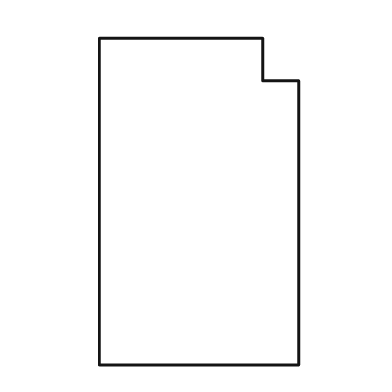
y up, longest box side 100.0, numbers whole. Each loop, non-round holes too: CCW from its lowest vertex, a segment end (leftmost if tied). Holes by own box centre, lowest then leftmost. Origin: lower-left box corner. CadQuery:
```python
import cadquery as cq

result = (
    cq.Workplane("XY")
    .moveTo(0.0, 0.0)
    .lineTo(61.0, 0.0)
    .lineTo(61.0, 87.0)
    .lineTo(50.0, 87.0)
    .lineTo(50.0, 100.0)
    .lineTo(0.0, 100.0)
    .close()
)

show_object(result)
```